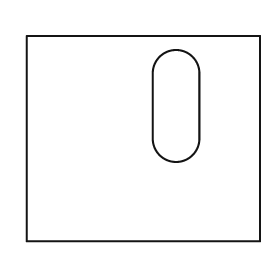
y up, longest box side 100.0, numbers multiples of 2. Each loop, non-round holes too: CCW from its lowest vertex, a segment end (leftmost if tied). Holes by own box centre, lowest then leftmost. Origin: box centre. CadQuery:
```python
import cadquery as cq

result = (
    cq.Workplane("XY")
    .moveTo(-50.0, -44.0)
    .lineTo(50.0, -44.0)
    .lineTo(50.0, 44.0)
    .lineTo(-50.0, 44.0)
    .close()
    .moveTo(4.0, 0.0)
    .threePointArc((14.0, -10.0), (24.0, 0.0))
    .lineTo(24.0, 28.0)
    .threePointArc((14.0, 38.0), (4.0, 28.0))
    .close()
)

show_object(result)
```